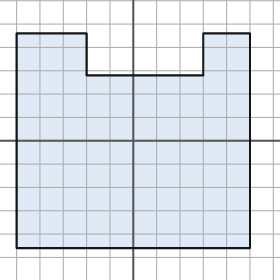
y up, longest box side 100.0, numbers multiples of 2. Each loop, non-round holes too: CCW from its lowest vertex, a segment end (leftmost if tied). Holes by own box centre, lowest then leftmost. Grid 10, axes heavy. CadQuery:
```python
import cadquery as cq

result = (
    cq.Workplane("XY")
    .moveTo(-50.0, -46.0)
    .lineTo(50.0, -46.0)
    .lineTo(50.0, 46.0)
    .lineTo(30.0, 46.0)
    .lineTo(30.0, 28.0)
    .lineTo(-20.0, 28.0)
    .lineTo(-20.0, 46.0)
    .lineTo(-50.0, 46.0)
    .close()
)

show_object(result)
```